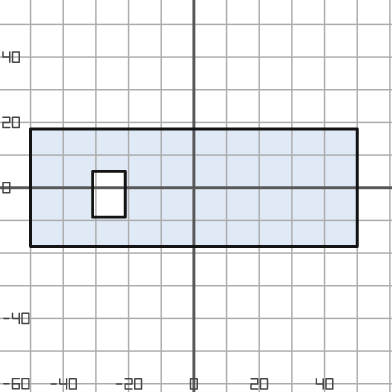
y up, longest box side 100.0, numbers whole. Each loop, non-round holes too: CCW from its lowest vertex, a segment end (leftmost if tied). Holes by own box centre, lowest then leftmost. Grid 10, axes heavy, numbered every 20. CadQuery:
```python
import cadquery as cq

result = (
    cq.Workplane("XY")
    .moveTo(-50.0, -18.0)
    .lineTo(50.0, -18.0)
    .lineTo(50.0, 18.0)
    .lineTo(-50.0, 18.0)
    .close()
    .moveTo(-31.0, -9.0)
    .lineTo(-21.0, -9.0)
    .lineTo(-21.0, 5.0)
    .lineTo(-31.0, 5.0)
    .close()
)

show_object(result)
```